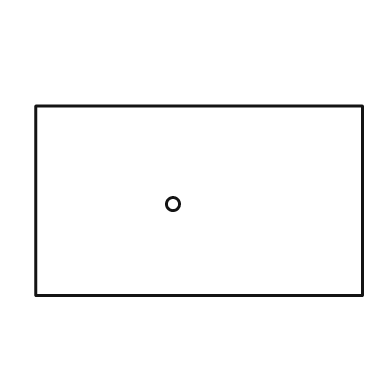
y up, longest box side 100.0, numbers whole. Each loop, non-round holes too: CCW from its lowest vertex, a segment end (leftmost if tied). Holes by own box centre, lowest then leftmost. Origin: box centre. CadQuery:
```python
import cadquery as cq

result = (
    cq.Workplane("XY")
    .moveTo(-50.0, -29.0)
    .lineTo(50.0, -29.0)
    .lineTo(50.0, 29.0)
    .lineTo(-50.0, 29.0)
    .close()
    .moveTo(-8.0, -1.0)
    .circle(2.0)
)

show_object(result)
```